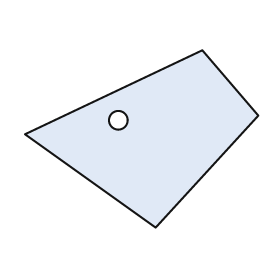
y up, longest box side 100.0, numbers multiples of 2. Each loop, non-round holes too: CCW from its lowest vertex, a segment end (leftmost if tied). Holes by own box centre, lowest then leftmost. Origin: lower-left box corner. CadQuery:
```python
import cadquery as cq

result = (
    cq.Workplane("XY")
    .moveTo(56.0, 0.0)
    .lineTo(100.0, 48.0)
    .lineTo(76.0, 76.0)
    .lineTo(0.0, 40.0)
    .close()
    .moveTo(40.0, 46.0)
    .circle(4.0)
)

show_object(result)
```